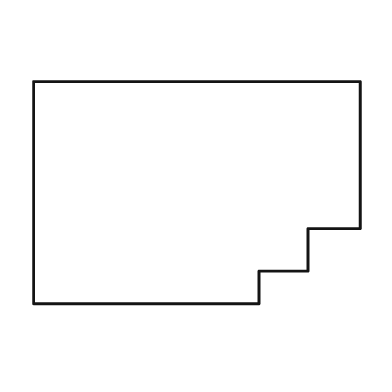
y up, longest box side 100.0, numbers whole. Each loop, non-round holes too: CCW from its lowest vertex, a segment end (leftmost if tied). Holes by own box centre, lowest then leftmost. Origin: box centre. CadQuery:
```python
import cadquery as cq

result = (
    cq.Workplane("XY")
    .moveTo(-50.0, -34.0)
    .lineTo(19.0, -34.0)
    .lineTo(19.0, -24.0)
    .lineTo(34.0, -24.0)
    .lineTo(34.0, -11.0)
    .lineTo(50.0, -11.0)
    .lineTo(50.0, 34.0)
    .lineTo(-50.0, 34.0)
    .close()
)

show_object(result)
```